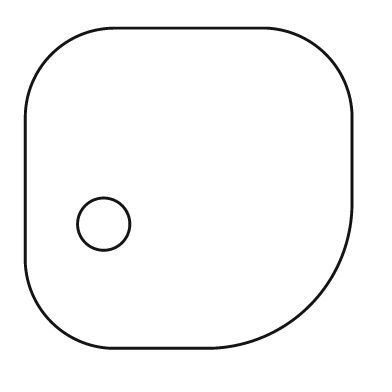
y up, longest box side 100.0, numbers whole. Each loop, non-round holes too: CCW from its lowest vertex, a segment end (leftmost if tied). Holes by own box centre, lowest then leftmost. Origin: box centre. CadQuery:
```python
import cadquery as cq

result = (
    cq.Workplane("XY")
    .moveTo(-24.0, -49.0)
    .lineTo(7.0, -49.0)
    .threePointArc((37.0, -36.0), (50.0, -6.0))
    .lineTo(50.0, 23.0)
    .threePointArc((42.0, 41.0), (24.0, 49.0))
    .lineTo(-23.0, 49.0)
    .threePointArc((-42.0, 41.0), (-50.0, 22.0))
    .lineTo(-50.0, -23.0)
    .threePointArc((-42.0, -41.0), (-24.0, -49.0))
    .close()
    .moveTo(-26.0, -11.0)
    .circle(8.0)
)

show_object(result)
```